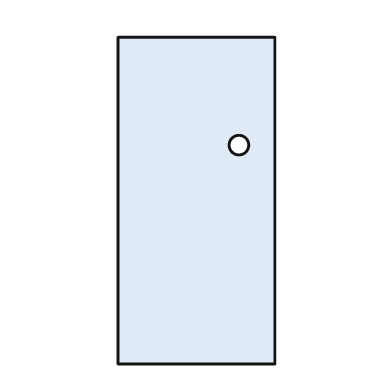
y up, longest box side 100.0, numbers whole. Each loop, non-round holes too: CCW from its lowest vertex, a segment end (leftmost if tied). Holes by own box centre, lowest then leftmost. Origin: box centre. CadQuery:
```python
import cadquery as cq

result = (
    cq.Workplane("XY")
    .moveTo(-24.0, -50.0)
    .lineTo(24.0, -50.0)
    .lineTo(24.0, 50.0)
    .lineTo(-24.0, 50.0)
    .close()
    .moveTo(13.0, 17.0)
    .circle(3.0)
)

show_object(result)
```